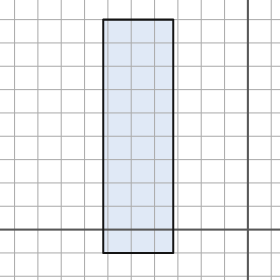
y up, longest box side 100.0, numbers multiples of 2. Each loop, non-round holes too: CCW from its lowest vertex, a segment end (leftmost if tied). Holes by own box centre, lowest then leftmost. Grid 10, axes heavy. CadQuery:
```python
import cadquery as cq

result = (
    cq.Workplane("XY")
    .moveTo(-62.0, -10.0)
    .lineTo(-32.0, -10.0)
    .lineTo(-32.0, 90.0)
    .lineTo(-62.0, 90.0)
    .close()
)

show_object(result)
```